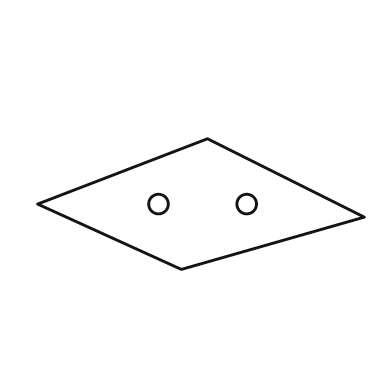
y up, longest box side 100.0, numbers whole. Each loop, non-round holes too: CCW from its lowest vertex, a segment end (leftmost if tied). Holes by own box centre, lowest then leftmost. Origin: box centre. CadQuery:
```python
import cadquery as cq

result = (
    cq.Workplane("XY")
    .moveTo(-6.0, -20.0)
    .lineTo(50.0, -4.0)
    .lineTo(2.0, 20.0)
    .lineTo(-50.0, 0.0)
    .close()
    .moveTo(-13.0, 0.0)
    .circle(3.0)
    .moveTo(14.0, 0.0)
    .circle(3.0)
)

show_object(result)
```